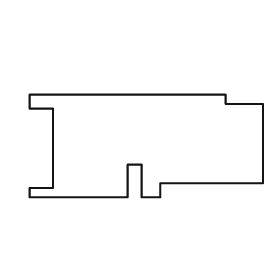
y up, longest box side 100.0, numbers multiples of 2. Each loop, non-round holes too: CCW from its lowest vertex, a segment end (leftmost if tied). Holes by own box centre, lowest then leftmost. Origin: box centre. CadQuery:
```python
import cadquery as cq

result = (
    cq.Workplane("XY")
    .moveTo(-50.0, -22.0)
    .lineTo(-8.0, -22.0)
    .lineTo(-8.0, -8.0)
    .lineTo(-2.0, -8.0)
    .lineTo(-2.0, -22.0)
    .lineTo(6.0, -22.0)
    .lineTo(6.0, -16.0)
    .lineTo(50.0, -16.0)
    .lineTo(50.0, 18.0)
    .lineTo(34.0, 18.0)
    .lineTo(34.0, 22.0)
    .lineTo(-50.0, 22.0)
    .lineTo(-50.0, 16.0)
    .lineTo(-40.0, 16.0)
    .lineTo(-40.0, -18.0)
    .lineTo(-50.0, -18.0)
    .close()
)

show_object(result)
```